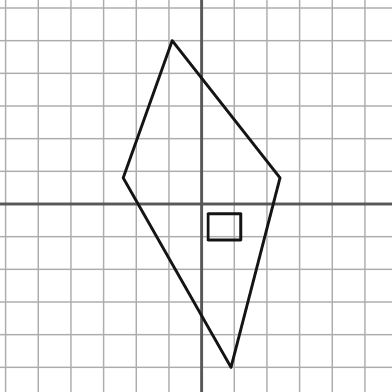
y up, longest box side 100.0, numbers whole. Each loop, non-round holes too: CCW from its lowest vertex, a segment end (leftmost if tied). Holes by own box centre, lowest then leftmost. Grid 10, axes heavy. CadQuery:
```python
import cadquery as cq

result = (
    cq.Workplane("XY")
    .moveTo(9.0, -50.0)
    .lineTo(24.0, 8.0)
    .lineTo(-9.0, 50.0)
    .lineTo(-24.0, 8.0)
    .close()
    .moveTo(2.0, -11.0)
    .lineTo(12.0, -11.0)
    .lineTo(12.0, -3.0)
    .lineTo(2.0, -3.0)
    .close()
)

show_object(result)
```